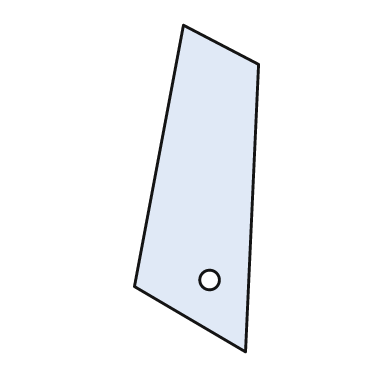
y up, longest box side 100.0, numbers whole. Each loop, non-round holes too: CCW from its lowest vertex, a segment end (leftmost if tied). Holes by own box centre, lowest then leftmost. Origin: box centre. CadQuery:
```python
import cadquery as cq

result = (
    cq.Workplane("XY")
    .moveTo(15.0, -50.0)
    .lineTo(19.0, 38.0)
    .lineTo(-4.0, 50.0)
    .lineTo(-19.0, -30.0)
    .close()
    .moveTo(4.0, -28.0)
    .circle(3.0)
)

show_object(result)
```